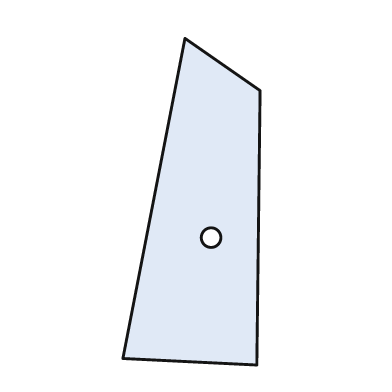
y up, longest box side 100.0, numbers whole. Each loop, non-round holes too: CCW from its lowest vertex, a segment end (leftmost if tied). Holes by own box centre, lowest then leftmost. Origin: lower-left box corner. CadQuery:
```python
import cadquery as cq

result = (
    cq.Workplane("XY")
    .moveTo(41.0, 0.0)
    .lineTo(42.0, 84.0)
    .lineTo(19.0, 100.0)
    .lineTo(0.0, 2.0)
    .close()
    .moveTo(27.0, 39.0)
    .circle(3.0)
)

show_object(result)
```